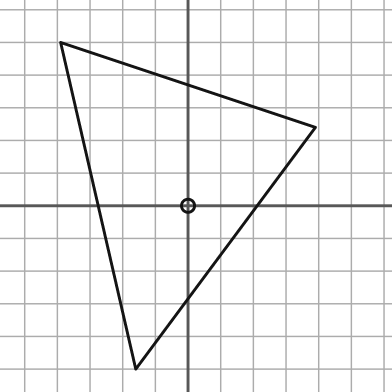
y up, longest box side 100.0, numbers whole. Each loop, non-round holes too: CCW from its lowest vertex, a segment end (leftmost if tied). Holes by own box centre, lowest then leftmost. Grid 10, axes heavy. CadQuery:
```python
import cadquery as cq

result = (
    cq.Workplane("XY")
    .moveTo(-16.0, -50.0)
    .lineTo(39.0, 24.0)
    .lineTo(-39.0, 50.0)
    .close()
    .moveTo(0.0, 0.0)
    .circle(2.0)
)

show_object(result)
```